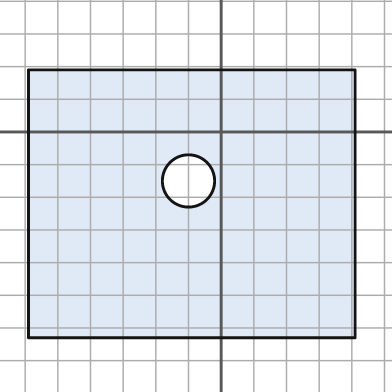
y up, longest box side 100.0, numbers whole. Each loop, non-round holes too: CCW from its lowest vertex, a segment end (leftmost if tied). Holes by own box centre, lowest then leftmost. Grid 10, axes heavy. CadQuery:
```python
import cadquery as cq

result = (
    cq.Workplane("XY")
    .moveTo(-59.0, -63.0)
    .lineTo(41.0, -63.0)
    .lineTo(41.0, 19.0)
    .lineTo(-59.0, 19.0)
    .close()
    .moveTo(-10.0, -15.0)
    .circle(8.0)
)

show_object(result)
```